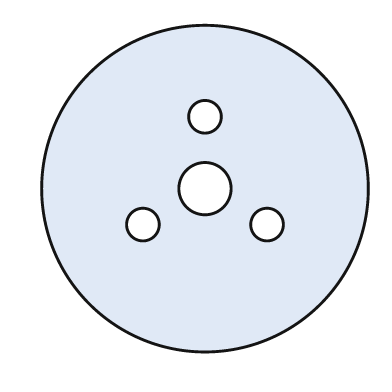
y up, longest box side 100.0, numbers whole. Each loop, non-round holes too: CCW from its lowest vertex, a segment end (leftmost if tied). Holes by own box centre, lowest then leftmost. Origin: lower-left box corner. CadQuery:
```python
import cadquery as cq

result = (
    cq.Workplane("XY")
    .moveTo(50.0, 50.0)
    .circle(50.0)
    .moveTo(31.0, 39.0)
    .circle(5.0)
    .moveTo(69.0, 39.0)
    .circle(5.0)
    .moveTo(50.0, 50.0)
    .circle(8.0)
    .moveTo(50.0, 72.0)
    .circle(5.0)
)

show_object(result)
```